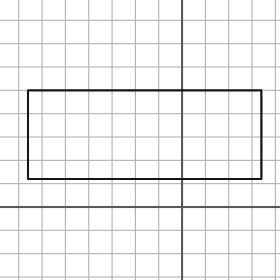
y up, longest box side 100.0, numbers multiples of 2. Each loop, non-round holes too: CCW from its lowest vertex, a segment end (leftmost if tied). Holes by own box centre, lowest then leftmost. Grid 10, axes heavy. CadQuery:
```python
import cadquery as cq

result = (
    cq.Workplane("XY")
    .moveTo(-66.0, 12.0)
    .lineTo(34.0, 12.0)
    .lineTo(34.0, 50.0)
    .lineTo(-66.0, 50.0)
    .close()
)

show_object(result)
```